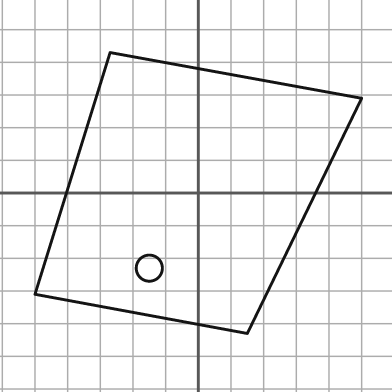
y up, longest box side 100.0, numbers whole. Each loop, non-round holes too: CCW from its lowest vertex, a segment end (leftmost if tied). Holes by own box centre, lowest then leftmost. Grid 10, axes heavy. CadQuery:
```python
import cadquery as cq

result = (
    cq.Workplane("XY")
    .moveTo(15.0, -43.0)
    .lineTo(50.0, 29.0)
    .lineTo(-27.0, 43.0)
    .lineTo(-50.0, -31.0)
    .close()
    .moveTo(-15.0, -23.0)
    .circle(4.0)
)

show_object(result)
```